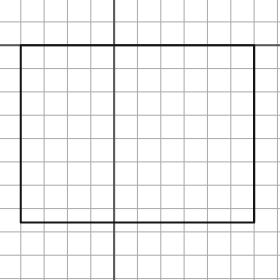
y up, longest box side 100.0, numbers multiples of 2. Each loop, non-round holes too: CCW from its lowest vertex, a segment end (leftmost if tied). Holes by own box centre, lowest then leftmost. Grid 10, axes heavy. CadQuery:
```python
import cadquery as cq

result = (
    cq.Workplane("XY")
    .moveTo(-40.0, -76.0)
    .lineTo(60.0, -76.0)
    .lineTo(60.0, 0.0)
    .lineTo(-40.0, 0.0)
    .close()
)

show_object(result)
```